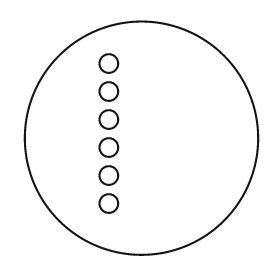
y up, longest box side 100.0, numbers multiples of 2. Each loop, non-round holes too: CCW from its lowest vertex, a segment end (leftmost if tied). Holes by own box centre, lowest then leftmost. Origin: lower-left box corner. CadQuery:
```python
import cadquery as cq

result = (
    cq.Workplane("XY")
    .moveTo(50.0, 50.0)
    .circle(50.0)
    .moveTo(36.0, 22.0)
    .circle(4.0)
    .moveTo(36.0, 34.0)
    .circle(4.0)
    .moveTo(36.0, 46.0)
    .circle(4.0)
    .moveTo(36.0, 58.0)
    .circle(4.0)
    .moveTo(36.0, 70.0)
    .circle(4.0)
    .moveTo(36.0, 82.0)
    .circle(4.0)
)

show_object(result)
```